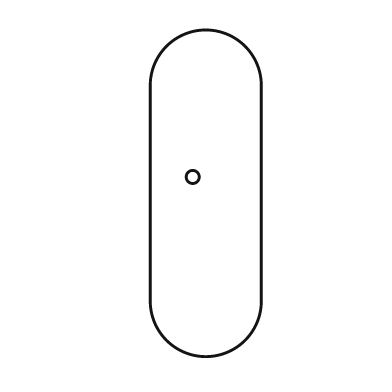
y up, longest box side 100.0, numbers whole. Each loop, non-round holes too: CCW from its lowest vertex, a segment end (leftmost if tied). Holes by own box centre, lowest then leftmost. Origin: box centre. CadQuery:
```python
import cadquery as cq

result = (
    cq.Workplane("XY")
    .moveTo(-17.0, -33.0)
    .threePointArc((0.0, -50.0), (17.0, -33.0))
    .lineTo(17.0, 33.0)
    .threePointArc((0.0, 50.0), (-17.0, 33.0))
    .close()
    .moveTo(-4.0, 5.0)
    .circle(2.0)
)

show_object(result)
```